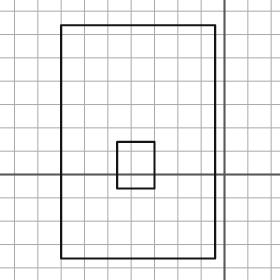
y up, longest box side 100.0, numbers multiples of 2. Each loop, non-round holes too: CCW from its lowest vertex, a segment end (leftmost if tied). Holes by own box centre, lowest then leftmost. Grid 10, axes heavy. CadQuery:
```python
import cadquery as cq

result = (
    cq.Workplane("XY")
    .moveTo(-70.0, -36.0)
    .lineTo(-4.0, -36.0)
    .lineTo(-4.0, 64.0)
    .lineTo(-70.0, 64.0)
    .close()
    .moveTo(-46.0, -6.0)
    .lineTo(-30.0, -6.0)
    .lineTo(-30.0, 14.0)
    .lineTo(-46.0, 14.0)
    .close()
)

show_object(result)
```